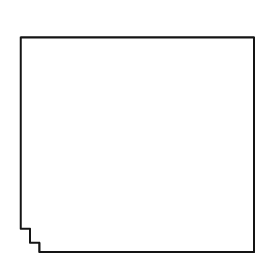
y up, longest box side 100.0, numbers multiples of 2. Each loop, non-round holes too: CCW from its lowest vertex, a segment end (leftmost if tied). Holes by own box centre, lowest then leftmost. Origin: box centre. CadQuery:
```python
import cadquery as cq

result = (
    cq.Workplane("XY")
    .moveTo(-42.0, -46.0)
    .lineTo(50.0, -46.0)
    .lineTo(50.0, 46.0)
    .lineTo(-50.0, 46.0)
    .lineTo(-50.0, -36.0)
    .lineTo(-46.0, -36.0)
    .lineTo(-46.0, -42.0)
    .lineTo(-42.0, -42.0)
    .close()
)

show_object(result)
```